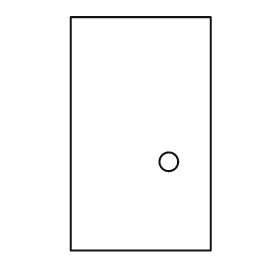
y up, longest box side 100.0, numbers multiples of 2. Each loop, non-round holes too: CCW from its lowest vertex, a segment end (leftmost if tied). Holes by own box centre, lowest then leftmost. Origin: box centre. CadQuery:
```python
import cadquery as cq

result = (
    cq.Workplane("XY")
    .moveTo(-30.0, -50.0)
    .lineTo(30.0, -50.0)
    .lineTo(30.0, 50.0)
    .lineTo(-30.0, 50.0)
    .close()
    .moveTo(12.0, -12.0)
    .circle(4.0)
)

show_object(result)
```